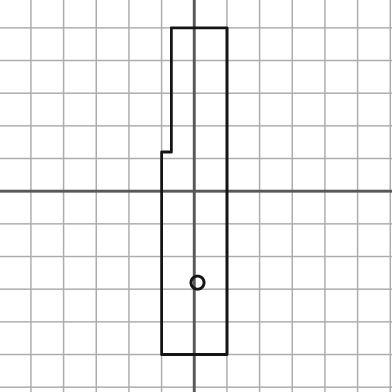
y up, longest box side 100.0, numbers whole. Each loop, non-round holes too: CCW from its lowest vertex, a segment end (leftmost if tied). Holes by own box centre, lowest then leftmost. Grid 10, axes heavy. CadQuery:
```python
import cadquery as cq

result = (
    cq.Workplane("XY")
    .moveTo(-10.0, -50.0)
    .lineTo(10.0, -50.0)
    .lineTo(10.0, 50.0)
    .lineTo(-7.0, 50.0)
    .lineTo(-7.0, 12.0)
    .lineTo(-10.0, 12.0)
    .close()
    .moveTo(1.0, -28.0)
    .circle(2.0)
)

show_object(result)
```